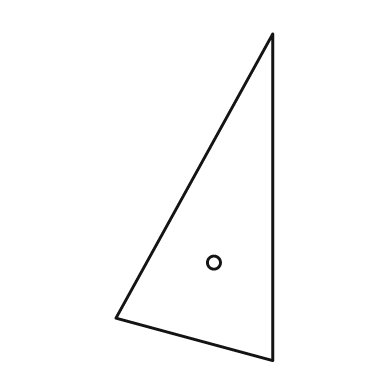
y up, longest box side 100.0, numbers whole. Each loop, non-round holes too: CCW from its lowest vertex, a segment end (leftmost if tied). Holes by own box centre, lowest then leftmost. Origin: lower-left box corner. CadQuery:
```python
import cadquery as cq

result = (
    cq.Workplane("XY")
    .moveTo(48.0, 0.0)
    .lineTo(48.0, 100.0)
    .lineTo(0.0, 13.0)
    .close()
    .moveTo(30.0, 30.0)
    .circle(2.0)
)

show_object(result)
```